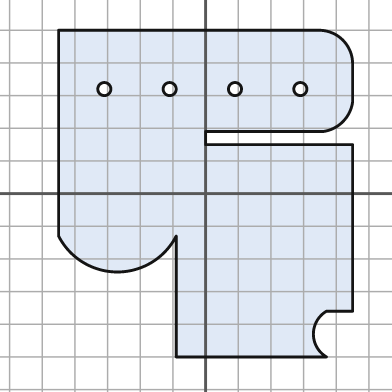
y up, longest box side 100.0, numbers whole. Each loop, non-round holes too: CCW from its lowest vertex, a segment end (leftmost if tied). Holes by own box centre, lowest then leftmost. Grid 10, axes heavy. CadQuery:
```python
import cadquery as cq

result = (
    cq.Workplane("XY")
    .moveTo(-9.0, -50.0)
    .lineTo(37.0, -50.0)
    .threePointArc((33.0, -43.0), (37.0, -36.0))
    .lineTo(45.0, -36.0)
    .lineTo(45.0, 15.0)
    .lineTo(0.0, 15.0)
    .lineTo(0.0, 19.0)
    .lineTo(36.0, 19.0)
    .threePointArc((42.0, 22.0), (45.0, 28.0))
    .lineTo(45.0, 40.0)
    .threePointArc((42.0, 47.0), (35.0, 50.0))
    .lineTo(-45.0, 50.0)
    .lineTo(-45.0, -13.0)
    .threePointArc((-27.0, -24.0), (-9.0, -13.0))
    .close()
    .moveTo(-31.0, 32.0)
    .circle(2.0)
    .moveTo(-11.0, 32.0)
    .circle(2.0)
    .moveTo(9.0, 32.0)
    .circle(2.0)
    .moveTo(29.0, 32.0)
    .circle(2.0)
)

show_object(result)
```